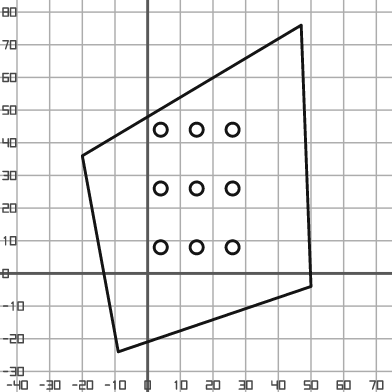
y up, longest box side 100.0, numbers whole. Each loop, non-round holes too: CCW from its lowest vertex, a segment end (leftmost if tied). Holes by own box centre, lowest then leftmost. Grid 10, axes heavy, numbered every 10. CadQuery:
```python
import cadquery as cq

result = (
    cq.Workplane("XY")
    .moveTo(-9.0, -24.0)
    .lineTo(50.0, -4.0)
    .lineTo(47.0, 76.0)
    .lineTo(-20.0, 36.0)
    .close()
    .moveTo(4.0, 8.0)
    .circle(2.0)
    .moveTo(15.0, 8.0)
    .circle(2.0)
    .moveTo(26.0, 8.0)
    .circle(2.0)
    .moveTo(4.0, 26.0)
    .circle(2.0)
    .moveTo(15.0, 26.0)
    .circle(2.0)
    .moveTo(26.0, 26.0)
    .circle(2.0)
    .moveTo(4.0, 44.0)
    .circle(2.0)
    .moveTo(15.0, 44.0)
    .circle(2.0)
    .moveTo(26.0, 44.0)
    .circle(2.0)
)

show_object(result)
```